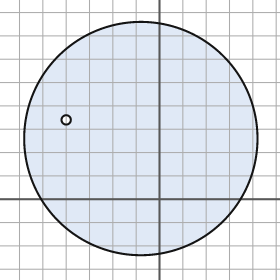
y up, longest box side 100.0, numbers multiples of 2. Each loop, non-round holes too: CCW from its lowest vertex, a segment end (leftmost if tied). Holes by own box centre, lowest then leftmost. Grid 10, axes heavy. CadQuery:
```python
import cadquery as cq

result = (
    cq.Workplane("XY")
    .moveTo(-8.0, 26.0)
    .circle(50.0)
    .moveTo(-40.0, 34.0)
    .circle(2.0)
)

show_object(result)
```